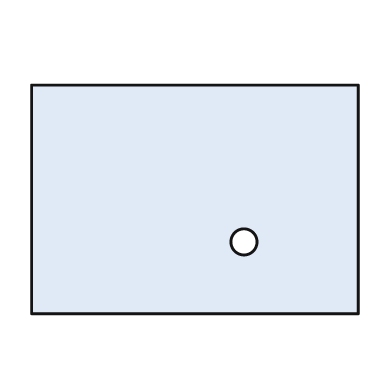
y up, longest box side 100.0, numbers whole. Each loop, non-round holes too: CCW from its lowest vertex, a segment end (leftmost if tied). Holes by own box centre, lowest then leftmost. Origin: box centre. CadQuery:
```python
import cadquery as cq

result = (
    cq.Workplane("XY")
    .moveTo(-50.0, -35.0)
    .lineTo(50.0, -35.0)
    .lineTo(50.0, 35.0)
    .lineTo(-50.0, 35.0)
    .close()
    .moveTo(15.0, -13.0)
    .circle(4.0)
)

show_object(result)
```